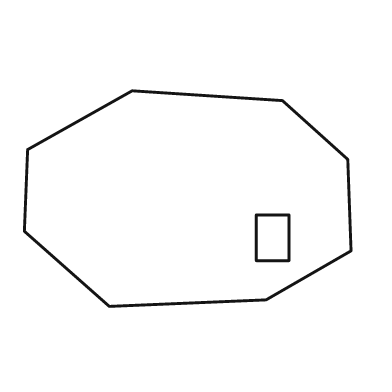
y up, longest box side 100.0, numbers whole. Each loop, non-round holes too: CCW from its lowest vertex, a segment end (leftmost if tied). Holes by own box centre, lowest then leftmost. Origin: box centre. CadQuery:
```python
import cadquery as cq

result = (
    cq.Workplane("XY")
    .moveTo(-24.0, -33.0)
    .lineTo(24.0, -31.0)
    .lineTo(50.0, -16.0)
    .lineTo(49.0, 12.0)
    .lineTo(29.0, 30.0)
    .lineTo(-17.0, 33.0)
    .lineTo(-49.0, 15.0)
    .lineTo(-50.0, -10.0)
    .close()
    .moveTo(21.0, -19.0)
    .lineTo(31.0, -19.0)
    .lineTo(31.0, -5.0)
    .lineTo(21.0, -5.0)
    .close()
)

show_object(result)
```